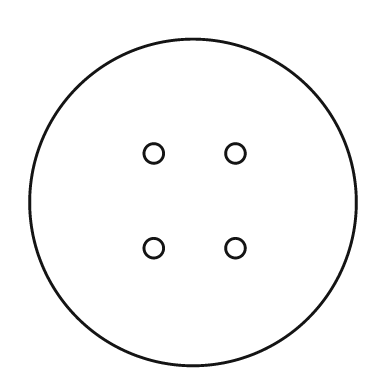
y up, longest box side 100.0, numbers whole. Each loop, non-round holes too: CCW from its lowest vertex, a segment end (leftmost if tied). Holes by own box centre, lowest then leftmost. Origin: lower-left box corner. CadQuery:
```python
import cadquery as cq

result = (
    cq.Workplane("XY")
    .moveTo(50.0, 50.0)
    .circle(50.0)
    .moveTo(38.0, 36.0)
    .circle(3.0)
    .moveTo(63.0, 36.0)
    .circle(3.0)
    .moveTo(38.0, 65.0)
    .circle(3.0)
    .moveTo(63.0, 65.0)
    .circle(3.0)
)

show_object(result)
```